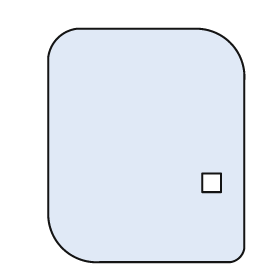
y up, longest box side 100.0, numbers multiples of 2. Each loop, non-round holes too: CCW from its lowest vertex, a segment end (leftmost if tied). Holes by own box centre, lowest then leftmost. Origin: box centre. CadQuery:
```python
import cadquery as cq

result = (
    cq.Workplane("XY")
    .moveTo(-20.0, -50.0)
    .lineTo(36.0, -50.0)
    .threePointArc((40.0, -48.0), (42.0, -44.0))
    .lineTo(42.0, 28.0)
    .threePointArc((36.0, 44.0), (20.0, 50.0))
    .lineTo(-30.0, 50.0)
    .threePointArc((-38.0, 46.0), (-42.0, 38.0))
    .lineTo(-42.0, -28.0)
    .threePointArc((-36.0, -44.0), (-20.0, -50.0))
    .close()
    .moveTo(24.0, -20.0)
    .lineTo(32.0, -20.0)
    .lineTo(32.0, -12.0)
    .lineTo(24.0, -12.0)
    .close()
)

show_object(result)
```